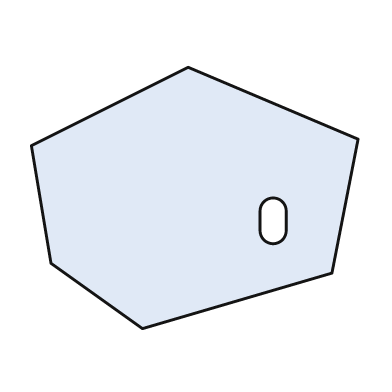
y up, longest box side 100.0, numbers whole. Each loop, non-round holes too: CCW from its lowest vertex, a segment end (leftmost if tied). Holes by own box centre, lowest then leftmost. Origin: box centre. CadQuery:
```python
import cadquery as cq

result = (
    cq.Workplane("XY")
    .moveTo(-16.0, -40.0)
    .lineTo(42.0, -23.0)
    .lineTo(50.0, 18.0)
    .lineTo(-2.0, 40.0)
    .lineTo(-50.0, 16.0)
    .lineTo(-44.0, -20.0)
    .close()
    .moveTo(20.0, -10.0)
    .threePointArc((24.0, -14.0), (28.0, -10.0))
    .lineTo(28.0, -4.0)
    .threePointArc((24.0, 0.0), (20.0, -4.0))
    .close()
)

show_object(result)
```